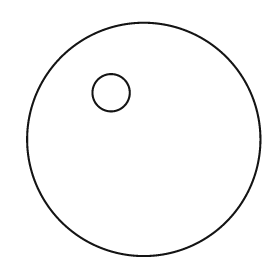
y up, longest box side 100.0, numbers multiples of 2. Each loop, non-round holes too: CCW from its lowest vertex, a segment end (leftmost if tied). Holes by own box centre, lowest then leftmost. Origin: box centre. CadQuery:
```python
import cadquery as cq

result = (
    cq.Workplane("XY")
    .moveTo(0.0, 0.0)
    .circle(50.0)
    .moveTo(-14.0, 20.0)
    .circle(8.0)
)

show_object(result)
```